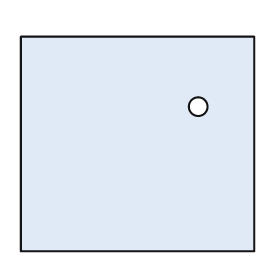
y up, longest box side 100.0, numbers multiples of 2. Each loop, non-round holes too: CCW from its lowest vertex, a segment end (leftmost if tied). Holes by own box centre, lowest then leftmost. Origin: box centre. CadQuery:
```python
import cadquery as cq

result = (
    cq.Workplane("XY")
    .moveTo(-50.0, -46.0)
    .lineTo(50.0, -46.0)
    .lineTo(50.0, 46.0)
    .lineTo(-50.0, 46.0)
    .close()
    .moveTo(26.0, 16.0)
    .circle(4.0)
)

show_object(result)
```